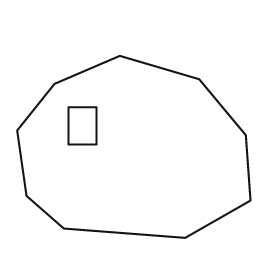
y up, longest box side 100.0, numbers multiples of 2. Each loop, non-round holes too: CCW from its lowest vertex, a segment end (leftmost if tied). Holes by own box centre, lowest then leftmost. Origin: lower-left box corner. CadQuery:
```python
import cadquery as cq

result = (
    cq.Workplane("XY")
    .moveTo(72.0, 0.0)
    .lineTo(100.0, 16.0)
    .lineTo(98.0, 44.0)
    .lineTo(78.0, 68.0)
    .lineTo(44.0, 78.0)
    .lineTo(16.0, 66.0)
    .lineTo(0.0, 46.0)
    .lineTo(4.0, 18.0)
    .lineTo(20.0, 4.0)
    .close()
    .moveTo(22.0, 40.0)
    .lineTo(34.0, 40.0)
    .lineTo(34.0, 56.0)
    .lineTo(22.0, 56.0)
    .close()
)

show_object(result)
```